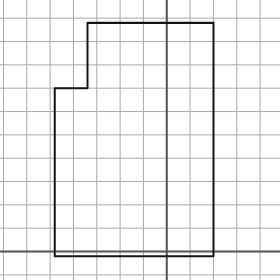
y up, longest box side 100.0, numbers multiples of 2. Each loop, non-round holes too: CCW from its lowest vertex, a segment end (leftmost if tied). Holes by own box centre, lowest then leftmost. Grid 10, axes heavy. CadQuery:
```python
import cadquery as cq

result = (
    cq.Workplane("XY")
    .moveTo(-48.0, -2.0)
    .lineTo(20.0, -2.0)
    .lineTo(20.0, 98.0)
    .lineTo(-34.0, 98.0)
    .lineTo(-34.0, 70.0)
    .lineTo(-48.0, 70.0)
    .close()
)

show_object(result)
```